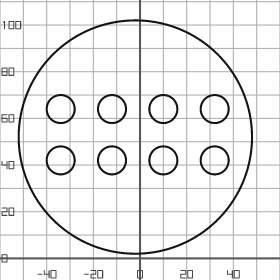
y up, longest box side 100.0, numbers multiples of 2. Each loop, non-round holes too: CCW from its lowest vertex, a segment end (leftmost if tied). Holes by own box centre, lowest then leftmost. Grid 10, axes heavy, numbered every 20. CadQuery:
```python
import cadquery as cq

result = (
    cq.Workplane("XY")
    .moveTo(-2.0, 52.0)
    .circle(50.0)
    .moveTo(-34.0, 42.0)
    .circle(6.0)
    .moveTo(-12.0, 42.0)
    .circle(6.0)
    .moveTo(10.0, 42.0)
    .circle(6.0)
    .moveTo(32.0, 42.0)
    .circle(6.0)
    .moveTo(-34.0, 64.0)
    .circle(6.0)
    .moveTo(-12.0, 64.0)
    .circle(6.0)
    .moveTo(10.0, 64.0)
    .circle(6.0)
    .moveTo(32.0, 64.0)
    .circle(6.0)
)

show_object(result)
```